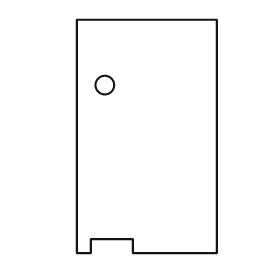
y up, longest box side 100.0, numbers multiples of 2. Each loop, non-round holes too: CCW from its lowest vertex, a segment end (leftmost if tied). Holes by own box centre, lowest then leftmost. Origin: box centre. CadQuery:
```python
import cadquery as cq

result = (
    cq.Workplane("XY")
    .moveTo(-30.0, -50.0)
    .lineTo(-24.0, -50.0)
    .lineTo(-24.0, -44.0)
    .lineTo(-6.0, -44.0)
    .lineTo(-6.0, -50.0)
    .lineTo(30.0, -50.0)
    .lineTo(30.0, 50.0)
    .lineTo(-30.0, 50.0)
    .close()
    .moveTo(-18.0, 22.0)
    .circle(4.0)
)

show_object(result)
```